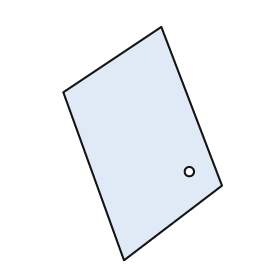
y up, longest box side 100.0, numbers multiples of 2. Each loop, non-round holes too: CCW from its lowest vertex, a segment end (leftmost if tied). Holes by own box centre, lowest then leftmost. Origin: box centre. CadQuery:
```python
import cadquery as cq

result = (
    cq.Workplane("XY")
    .moveTo(-8.0, -50.0)
    .lineTo(34.0, -18.0)
    .lineTo(8.0, 50.0)
    .lineTo(-34.0, 22.0)
    .close()
    .moveTo(20.0, -12.0)
    .circle(2.0)
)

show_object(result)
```